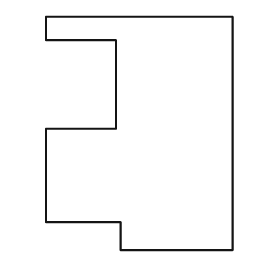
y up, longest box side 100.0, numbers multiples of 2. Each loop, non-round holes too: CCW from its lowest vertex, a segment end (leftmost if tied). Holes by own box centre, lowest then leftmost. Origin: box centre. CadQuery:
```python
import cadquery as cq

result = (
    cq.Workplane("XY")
    .moveTo(-8.0, -50.0)
    .lineTo(40.0, -50.0)
    .lineTo(40.0, 50.0)
    .lineTo(-40.0, 50.0)
    .lineTo(-40.0, 40.0)
    .lineTo(-10.0, 40.0)
    .lineTo(-10.0, 2.0)
    .lineTo(-40.0, 2.0)
    .lineTo(-40.0, -38.0)
    .lineTo(-8.0, -38.0)
    .close()
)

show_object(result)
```